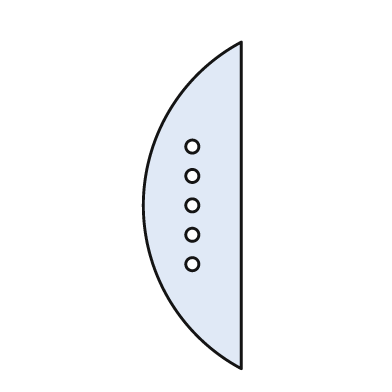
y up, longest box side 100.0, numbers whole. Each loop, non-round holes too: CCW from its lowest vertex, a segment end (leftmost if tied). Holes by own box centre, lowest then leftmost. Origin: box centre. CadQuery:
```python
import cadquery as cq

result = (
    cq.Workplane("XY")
    .moveTo(15.0, -50.0)
    .lineTo(15.0, 50.0)
    .threePointArc((-15.0, 0.0), (15.0, -50.0))
    .close()
    .moveTo(0.0, -18.0)
    .circle(2.0)
    .moveTo(0.0, -9.0)
    .circle(2.0)
    .moveTo(0.0, 0.0)
    .circle(2.0)
    .moveTo(0.0, 9.0)
    .circle(2.0)
    .moveTo(0.0, 18.0)
    .circle(2.0)
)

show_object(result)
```